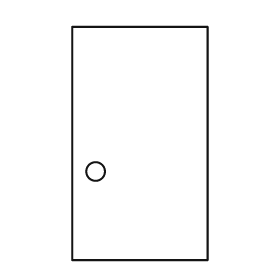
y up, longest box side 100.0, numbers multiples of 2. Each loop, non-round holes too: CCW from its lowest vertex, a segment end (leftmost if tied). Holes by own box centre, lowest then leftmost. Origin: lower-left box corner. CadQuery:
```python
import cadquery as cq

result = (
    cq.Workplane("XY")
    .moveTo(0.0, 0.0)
    .lineTo(58.0, 0.0)
    .lineTo(58.0, 100.0)
    .lineTo(0.0, 100.0)
    .close()
    .moveTo(10.0, 38.0)
    .circle(4.0)
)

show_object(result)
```